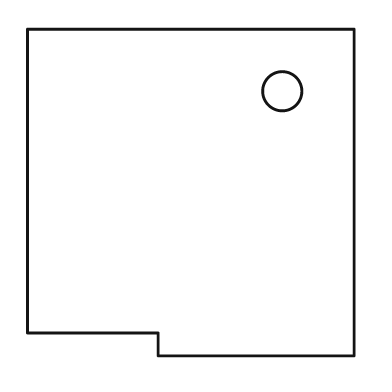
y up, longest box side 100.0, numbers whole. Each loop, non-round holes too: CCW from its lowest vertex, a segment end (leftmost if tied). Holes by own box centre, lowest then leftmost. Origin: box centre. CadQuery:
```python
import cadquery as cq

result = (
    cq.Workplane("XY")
    .moveTo(-10.0, -50.0)
    .lineTo(50.0, -50.0)
    .lineTo(50.0, 50.0)
    .lineTo(-50.0, 50.0)
    .lineTo(-50.0, -43.0)
    .lineTo(-10.0, -43.0)
    .close()
    .moveTo(28.0, 31.0)
    .circle(6.0)
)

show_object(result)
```